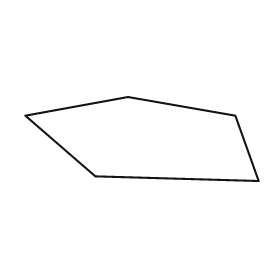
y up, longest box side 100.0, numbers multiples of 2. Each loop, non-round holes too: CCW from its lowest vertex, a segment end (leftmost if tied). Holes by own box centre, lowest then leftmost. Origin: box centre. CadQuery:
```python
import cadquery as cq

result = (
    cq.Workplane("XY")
    .moveTo(50.0, -18.0)
    .lineTo(40.0, 10.0)
    .lineTo(-6.0, 18.0)
    .lineTo(-50.0, 10.0)
    .lineTo(-20.0, -16.0)
    .close()
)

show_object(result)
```